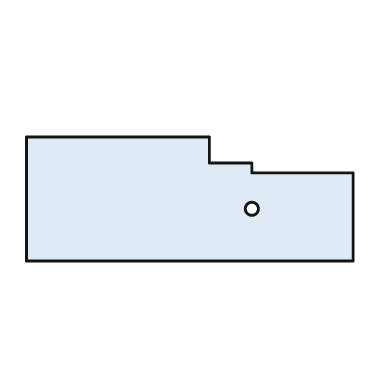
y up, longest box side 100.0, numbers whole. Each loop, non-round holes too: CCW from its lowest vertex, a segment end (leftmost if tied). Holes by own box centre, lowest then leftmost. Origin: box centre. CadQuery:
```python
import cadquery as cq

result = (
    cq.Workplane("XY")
    .moveTo(-50.0, -19.0)
    .lineTo(50.0, -19.0)
    .lineTo(50.0, 8.0)
    .lineTo(19.0, 8.0)
    .lineTo(19.0, 11.0)
    .lineTo(6.0, 11.0)
    .lineTo(6.0, 19.0)
    .lineTo(-50.0, 19.0)
    .close()
    .moveTo(19.0, -3.0)
    .circle(2.0)
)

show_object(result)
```